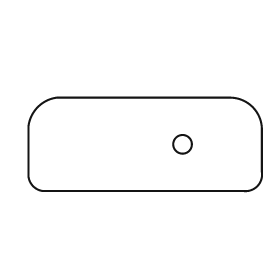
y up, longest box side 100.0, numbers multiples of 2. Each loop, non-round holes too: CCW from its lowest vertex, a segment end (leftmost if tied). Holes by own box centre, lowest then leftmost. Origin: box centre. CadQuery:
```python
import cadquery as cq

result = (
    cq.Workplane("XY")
    .moveTo(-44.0, -20.0)
    .lineTo(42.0, -20.0)
    .threePointArc((48.0, -18.0), (50.0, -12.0))
    .lineTo(50.0, 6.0)
    .threePointArc((46.0, 16.0), (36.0, 20.0))
    .lineTo(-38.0, 20.0)
    .threePointArc((-46.0, 16.0), (-50.0, 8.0))
    .lineTo(-50.0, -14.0)
    .threePointArc((-48.0, -18.0), (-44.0, -20.0))
    .close()
    .moveTo(16.0, 0.0)
    .circle(4.0)
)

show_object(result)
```